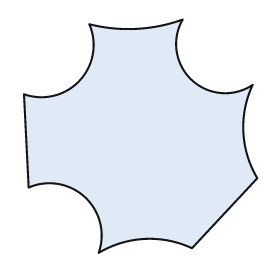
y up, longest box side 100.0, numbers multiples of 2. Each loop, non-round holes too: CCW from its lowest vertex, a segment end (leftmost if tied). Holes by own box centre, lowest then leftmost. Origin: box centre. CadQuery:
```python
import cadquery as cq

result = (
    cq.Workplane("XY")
    .moveTo(-18.0, -50.0)
    .threePointArc((2.0, -44.0), (22.0, -48.0))
    .lineTo(50.0, -18.0)
    .threePointArc((44.0, 2.0), (48.0, 22.0))
    .threePointArc((22.0, 24.0), (18.0, 50.0))
    .threePointArc((-2.0, 46.0), (-22.0, 48.0))
    .threePointArc((-26.0, 24.0), (-50.0, 18.0))
    .lineTo(-48.0, -22.0)
    .threePointArc((-24.0, -26.0), (-18.0, -50.0))
    .close()
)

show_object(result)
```